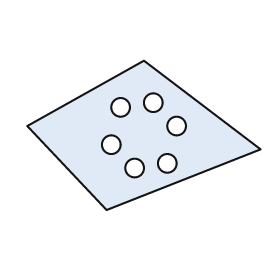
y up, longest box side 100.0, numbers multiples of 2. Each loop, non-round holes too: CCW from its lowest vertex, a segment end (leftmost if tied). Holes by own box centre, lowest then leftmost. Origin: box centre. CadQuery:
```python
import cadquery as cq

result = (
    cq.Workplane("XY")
    .moveTo(-16.0, -32.0)
    .lineTo(50.0, -6.0)
    .lineTo(0.0, 32.0)
    .lineTo(-50.0, 4.0)
    .close()
    .moveTo(-4.0, -14.0)
    .circle(4.0)
    .moveTo(10.0, -12.0)
    .circle(4.0)
    .moveTo(-14.0, -4.0)
    .circle(4.0)
    .moveTo(14.0, 4.0)
    .circle(4.0)
    .moveTo(-10.0, 12.0)
    .circle(4.0)
    .moveTo(4.0, 14.0)
    .circle(4.0)
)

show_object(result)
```